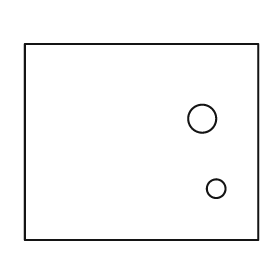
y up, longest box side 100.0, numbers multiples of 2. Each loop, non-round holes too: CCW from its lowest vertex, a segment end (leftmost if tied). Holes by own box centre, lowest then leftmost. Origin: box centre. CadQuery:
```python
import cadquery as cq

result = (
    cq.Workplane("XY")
    .moveTo(-50.0, -42.0)
    .lineTo(50.0, -42.0)
    .lineTo(50.0, 42.0)
    .lineTo(-50.0, 42.0)
    .close()
    .moveTo(32.0, -20.0)
    .circle(4.0)
    .moveTo(26.0, 10.0)
    .circle(6.0)
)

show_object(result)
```